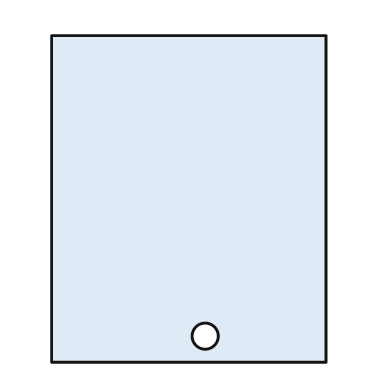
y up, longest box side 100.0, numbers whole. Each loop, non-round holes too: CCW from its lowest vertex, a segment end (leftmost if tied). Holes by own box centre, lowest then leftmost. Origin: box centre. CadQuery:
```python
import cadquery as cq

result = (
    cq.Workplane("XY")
    .moveTo(-42.0, -50.0)
    .lineTo(42.0, -50.0)
    .lineTo(42.0, 50.0)
    .lineTo(-42.0, 50.0)
    .close()
    .moveTo(5.0, -42.0)
    .circle(4.0)
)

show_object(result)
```